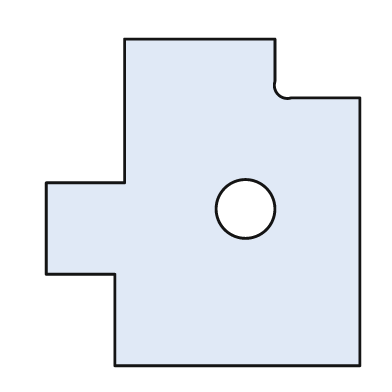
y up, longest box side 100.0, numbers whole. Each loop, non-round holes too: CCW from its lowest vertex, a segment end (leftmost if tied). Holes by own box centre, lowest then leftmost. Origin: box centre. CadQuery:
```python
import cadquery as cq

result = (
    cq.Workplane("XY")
    .moveTo(-27.0, -50.0)
    .lineTo(48.0, -50.0)
    .lineTo(48.0, 32.0)
    .lineTo(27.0, 32.0)
    .threePointArc((23.0, 33.0), (22.0, 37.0))
    .lineTo(22.0, 50.0)
    .lineTo(-24.0, 50.0)
    .lineTo(-24.0, 6.0)
    .lineTo(-48.0, 6.0)
    .lineTo(-48.0, -22.0)
    .lineTo(-27.0, -22.0)
    .close()
    .moveTo(13.0, -2.0)
    .circle(9.0)
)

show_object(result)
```